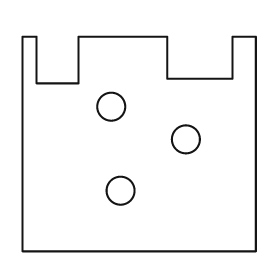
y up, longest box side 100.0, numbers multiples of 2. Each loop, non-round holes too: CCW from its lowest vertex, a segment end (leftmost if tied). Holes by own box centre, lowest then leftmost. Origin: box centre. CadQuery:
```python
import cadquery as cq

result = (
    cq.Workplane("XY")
    .moveTo(-50.0, -46.0)
    .lineTo(50.0, -46.0)
    .lineTo(50.0, 46.0)
    .lineTo(40.0, 46.0)
    .lineTo(40.0, 28.0)
    .lineTo(12.0, 28.0)
    .lineTo(12.0, 46.0)
    .lineTo(-26.0, 46.0)
    .lineTo(-26.0, 26.0)
    .lineTo(-44.0, 26.0)
    .lineTo(-44.0, 46.0)
    .lineTo(-50.0, 46.0)
    .close()
    .moveTo(-8.0, -20.0)
    .circle(6.0)
    .moveTo(20.0, 2.0)
    .circle(6.0)
    .moveTo(-12.0, 16.0)
    .circle(6.0)
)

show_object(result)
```